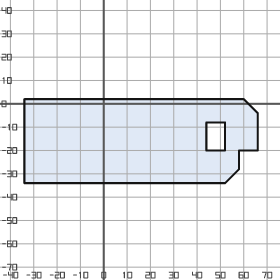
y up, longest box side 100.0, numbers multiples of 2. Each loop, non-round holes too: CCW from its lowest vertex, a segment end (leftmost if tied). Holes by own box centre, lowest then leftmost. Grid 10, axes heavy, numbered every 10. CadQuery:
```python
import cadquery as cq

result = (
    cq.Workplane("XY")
    .moveTo(-34.0, -34.0)
    .lineTo(52.0, -34.0)
    .lineTo(58.0, -28.0)
    .lineTo(58.0, -20.0)
    .lineTo(66.0, -20.0)
    .lineTo(66.0, -4.0)
    .lineTo(60.0, 2.0)
    .lineTo(-34.0, 2.0)
    .close()
    .moveTo(44.0, -20.0)
    .lineTo(52.0, -20.0)
    .lineTo(52.0, -8.0)
    .lineTo(44.0, -8.0)
    .close()
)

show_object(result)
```